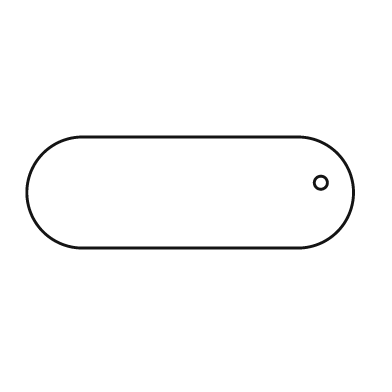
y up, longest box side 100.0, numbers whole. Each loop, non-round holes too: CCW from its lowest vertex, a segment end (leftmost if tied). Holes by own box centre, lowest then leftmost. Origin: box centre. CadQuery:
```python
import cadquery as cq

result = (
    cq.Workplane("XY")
    .moveTo(-33.0, -17.0)
    .lineTo(33.0, -17.0)
    .threePointArc((50.0, 0.0), (33.0, 17.0))
    .lineTo(-33.0, 17.0)
    .threePointArc((-50.0, 0.0), (-33.0, -17.0))
    .close()
    .moveTo(40.0, 3.0)
    .circle(2.0)
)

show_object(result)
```